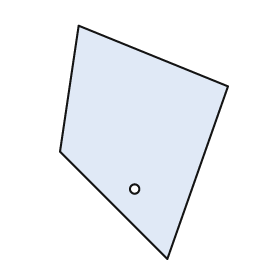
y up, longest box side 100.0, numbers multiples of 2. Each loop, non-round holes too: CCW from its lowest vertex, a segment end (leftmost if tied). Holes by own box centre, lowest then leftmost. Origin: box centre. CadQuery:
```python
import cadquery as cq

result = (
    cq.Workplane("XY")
    .moveTo(10.0, -50.0)
    .lineTo(36.0, 24.0)
    .lineTo(-28.0, 50.0)
    .lineTo(-36.0, -4.0)
    .close()
    .moveTo(-4.0, -20.0)
    .circle(2.0)
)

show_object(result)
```